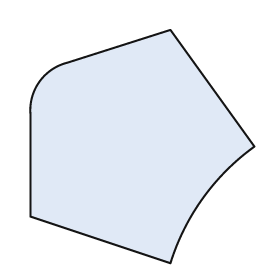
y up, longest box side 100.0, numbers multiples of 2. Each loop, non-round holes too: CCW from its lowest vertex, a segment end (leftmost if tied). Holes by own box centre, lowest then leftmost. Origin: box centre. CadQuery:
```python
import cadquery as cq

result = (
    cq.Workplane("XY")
    .moveTo(12.0, -50.0)
    .threePointArc((26.0, -22.0), (48.0, 0.0))
    .lineTo(12.0, 50.0)
    .lineTo(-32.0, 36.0)
    .threePointArc((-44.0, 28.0), (-48.0, 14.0))
    .lineTo(-48.0, -30.0)
    .close()
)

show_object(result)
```